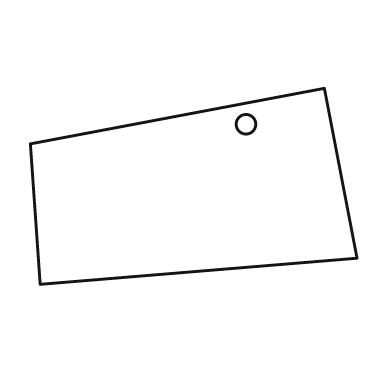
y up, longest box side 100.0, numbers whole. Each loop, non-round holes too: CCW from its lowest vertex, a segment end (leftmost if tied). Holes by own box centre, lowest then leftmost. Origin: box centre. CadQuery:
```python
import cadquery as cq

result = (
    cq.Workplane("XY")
    .moveTo(-47.0, -30.0)
    .lineTo(50.0, -22.0)
    .lineTo(40.0, 30.0)
    .lineTo(-50.0, 13.0)
    .close()
    .moveTo(16.0, 19.0)
    .circle(3.0)
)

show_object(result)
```